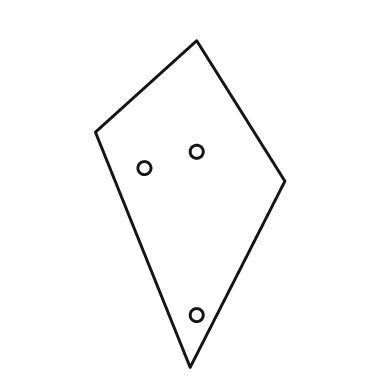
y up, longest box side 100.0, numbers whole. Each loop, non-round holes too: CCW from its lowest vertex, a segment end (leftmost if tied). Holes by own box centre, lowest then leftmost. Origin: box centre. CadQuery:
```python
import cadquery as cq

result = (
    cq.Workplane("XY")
    .moveTo(0.0, -50.0)
    .lineTo(29.0, 7.0)
    .lineTo(2.0, 50.0)
    .lineTo(-29.0, 22.0)
    .close()
    .moveTo(2.0, -34.0)
    .circle(2.0)
    .moveTo(-14.0, 11.0)
    .circle(2.0)
    .moveTo(2.0, 16.0)
    .circle(2.0)
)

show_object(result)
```